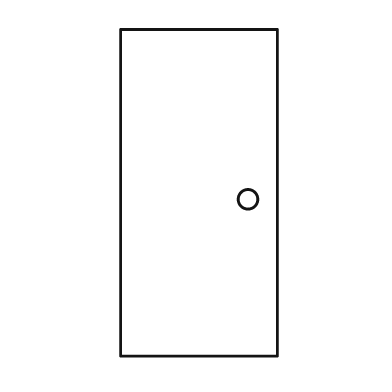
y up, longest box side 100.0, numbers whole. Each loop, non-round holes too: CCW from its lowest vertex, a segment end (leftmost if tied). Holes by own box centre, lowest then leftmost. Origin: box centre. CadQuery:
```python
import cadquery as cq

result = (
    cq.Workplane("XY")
    .moveTo(-24.0, -50.0)
    .lineTo(24.0, -50.0)
    .lineTo(24.0, 50.0)
    .lineTo(-24.0, 50.0)
    .close()
    .moveTo(15.0, -2.0)
    .circle(3.0)
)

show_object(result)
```